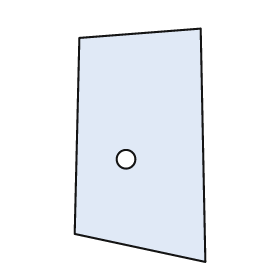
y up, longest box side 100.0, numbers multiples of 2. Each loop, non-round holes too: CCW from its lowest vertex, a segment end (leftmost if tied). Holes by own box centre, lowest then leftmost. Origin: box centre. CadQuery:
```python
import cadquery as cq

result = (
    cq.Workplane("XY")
    .moveTo(28.0, -50.0)
    .lineTo(26.0, 50.0)
    .lineTo(-26.0, 46.0)
    .lineTo(-28.0, -38.0)
    .close()
    .moveTo(-6.0, -6.0)
    .circle(4.0)
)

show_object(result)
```